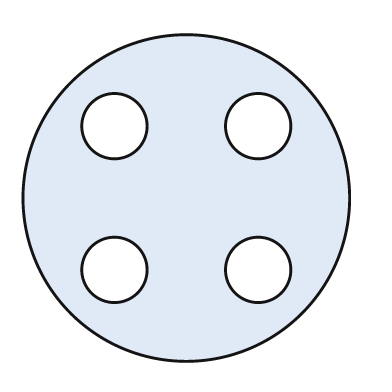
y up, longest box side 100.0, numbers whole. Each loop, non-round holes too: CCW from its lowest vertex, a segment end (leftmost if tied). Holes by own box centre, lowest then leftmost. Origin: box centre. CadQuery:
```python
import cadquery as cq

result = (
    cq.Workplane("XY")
    .moveTo(0.0, 0.0)
    .circle(50.0)
    .moveTo(-22.0, -22.0)
    .circle(10.0)
    .moveTo(22.0, -22.0)
    .circle(10.0)
    .moveTo(-22.0, 22.0)
    .circle(10.0)
    .moveTo(22.0, 22.0)
    .circle(10.0)
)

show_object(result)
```